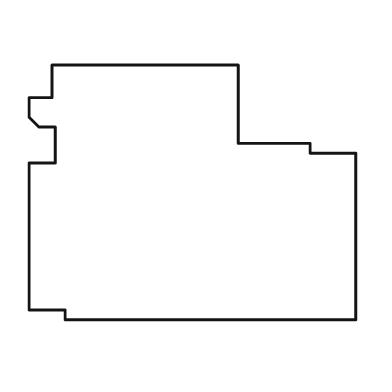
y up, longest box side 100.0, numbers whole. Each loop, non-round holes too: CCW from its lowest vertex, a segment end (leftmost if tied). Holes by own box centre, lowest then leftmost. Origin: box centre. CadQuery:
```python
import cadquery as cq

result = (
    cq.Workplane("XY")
    .moveTo(-39.0, -39.0)
    .lineTo(50.0, -39.0)
    .lineTo(50.0, 12.0)
    .lineTo(36.0, 12.0)
    .lineTo(36.0, 15.0)
    .lineTo(14.0, 15.0)
    .lineTo(14.0, 39.0)
    .lineTo(-43.0, 39.0)
    .lineTo(-43.0, 29.0)
    .lineTo(-50.0, 29.0)
    .lineTo(-50.0, 23.0)
    .lineTo(-47.0, 20.0)
    .lineTo(-42.0, 20.0)
    .lineTo(-42.0, 9.0)
    .lineTo(-50.0, 9.0)
    .lineTo(-50.0, -36.0)
    .lineTo(-39.0, -36.0)
    .close()
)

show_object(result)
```